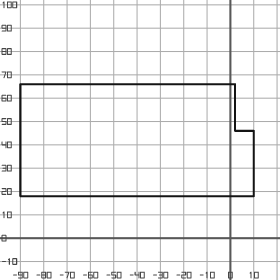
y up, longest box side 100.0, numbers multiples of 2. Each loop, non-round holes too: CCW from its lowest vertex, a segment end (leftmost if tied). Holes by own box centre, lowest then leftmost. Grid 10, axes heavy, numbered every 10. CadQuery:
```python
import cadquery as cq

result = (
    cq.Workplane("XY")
    .moveTo(-90.0, 18.0)
    .lineTo(10.0, 18.0)
    .lineTo(10.0, 46.0)
    .lineTo(2.0, 46.0)
    .lineTo(2.0, 66.0)
    .lineTo(-90.0, 66.0)
    .close()
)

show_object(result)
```